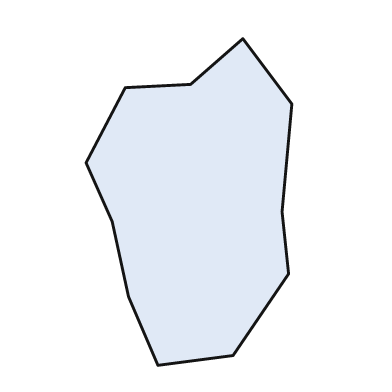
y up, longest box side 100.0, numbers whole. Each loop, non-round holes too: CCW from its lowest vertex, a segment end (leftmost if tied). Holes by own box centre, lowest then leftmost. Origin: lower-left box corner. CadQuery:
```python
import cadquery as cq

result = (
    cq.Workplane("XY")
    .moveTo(22.0, 0.0)
    .lineTo(45.0, 3.0)
    .lineTo(62.0, 28.0)
    .lineTo(60.0, 47.0)
    .lineTo(63.0, 80.0)
    .lineTo(48.0, 100.0)
    .lineTo(32.0, 86.0)
    .lineTo(12.0, 85.0)
    .lineTo(0.0, 62.0)
    .lineTo(8.0, 44.0)
    .lineTo(13.0, 21.0)
    .close()
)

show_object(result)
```